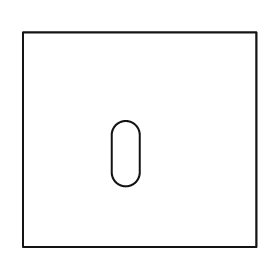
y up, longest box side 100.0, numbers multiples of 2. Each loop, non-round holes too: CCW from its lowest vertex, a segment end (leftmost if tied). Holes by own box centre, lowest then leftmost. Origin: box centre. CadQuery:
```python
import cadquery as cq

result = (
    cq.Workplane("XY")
    .moveTo(-50.0, -46.0)
    .lineTo(50.0, -46.0)
    .lineTo(50.0, 46.0)
    .lineTo(-50.0, 46.0)
    .close()
    .moveTo(-12.0, -14.0)
    .threePointArc((-6.0, -20.0), (0.0, -14.0))
    .lineTo(0.0, 2.0)
    .threePointArc((-6.0, 8.0), (-12.0, 2.0))
    .close()
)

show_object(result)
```